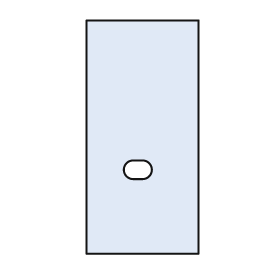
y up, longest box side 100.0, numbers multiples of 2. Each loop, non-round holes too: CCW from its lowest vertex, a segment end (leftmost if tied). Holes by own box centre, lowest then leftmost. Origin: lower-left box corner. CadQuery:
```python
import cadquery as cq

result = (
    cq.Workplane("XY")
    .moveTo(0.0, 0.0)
    .lineTo(48.0, 0.0)
    .lineTo(48.0, 100.0)
    .lineTo(0.0, 100.0)
    .close()
    .moveTo(20.0, 32.0)
    .lineTo(24.0, 32.0)
    .threePointArc((28.0, 36.0), (24.0, 40.0))
    .lineTo(20.0, 40.0)
    .threePointArc((16.0, 36.0), (20.0, 32.0))
    .close()
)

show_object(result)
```